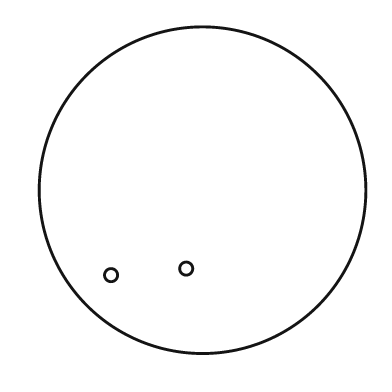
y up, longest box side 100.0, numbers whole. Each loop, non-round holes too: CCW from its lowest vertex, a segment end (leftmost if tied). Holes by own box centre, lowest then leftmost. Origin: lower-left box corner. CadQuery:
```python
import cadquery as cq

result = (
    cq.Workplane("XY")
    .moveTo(50.0, 50.0)
    .circle(50.0)
    .moveTo(22.0, 24.0)
    .circle(2.0)
    .moveTo(45.0, 26.0)
    .circle(2.0)
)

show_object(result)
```